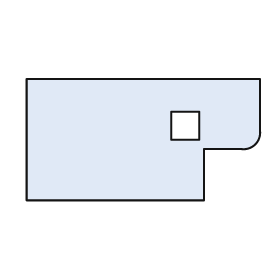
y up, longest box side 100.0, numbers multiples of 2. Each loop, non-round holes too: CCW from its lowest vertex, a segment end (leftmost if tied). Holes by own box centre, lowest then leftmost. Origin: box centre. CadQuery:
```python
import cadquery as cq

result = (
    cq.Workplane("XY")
    .moveTo(-50.0, -26.0)
    .lineTo(26.0, -26.0)
    .lineTo(26.0, -4.0)
    .lineTo(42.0, -4.0)
    .threePointArc((48.0, -2.0), (50.0, 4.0))
    .lineTo(50.0, 26.0)
    .lineTo(-50.0, 26.0)
    .close()
    .moveTo(12.0, 0.0)
    .lineTo(24.0, 0.0)
    .lineTo(24.0, 12.0)
    .lineTo(12.0, 12.0)
    .close()
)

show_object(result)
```